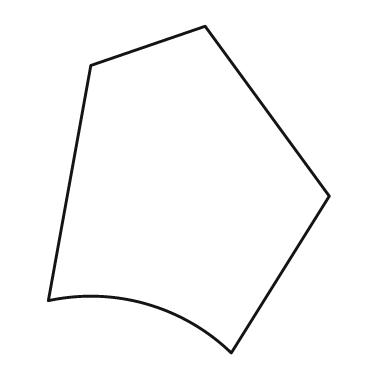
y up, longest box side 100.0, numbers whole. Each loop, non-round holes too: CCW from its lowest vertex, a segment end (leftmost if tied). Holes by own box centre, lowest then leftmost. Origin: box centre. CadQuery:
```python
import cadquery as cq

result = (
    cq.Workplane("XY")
    .moveTo(13.0, -50.0)
    .lineTo(43.0, -2.0)
    .lineTo(5.0, 50.0)
    .lineTo(-30.0, 38.0)
    .lineTo(-43.0, -34.0)
    .threePointArc((-13.0, -35.0), (13.0, -50.0))
    .close()
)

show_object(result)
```